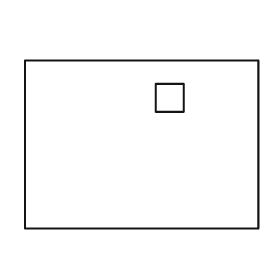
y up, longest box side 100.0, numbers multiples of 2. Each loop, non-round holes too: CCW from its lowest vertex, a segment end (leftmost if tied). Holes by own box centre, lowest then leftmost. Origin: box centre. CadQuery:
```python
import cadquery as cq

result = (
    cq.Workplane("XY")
    .moveTo(-50.0, -36.0)
    .lineTo(50.0, -36.0)
    .lineTo(50.0, 36.0)
    .lineTo(-50.0, 36.0)
    .close()
    .moveTo(6.0, 14.0)
    .lineTo(18.0, 14.0)
    .lineTo(18.0, 26.0)
    .lineTo(6.0, 26.0)
    .close()
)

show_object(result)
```